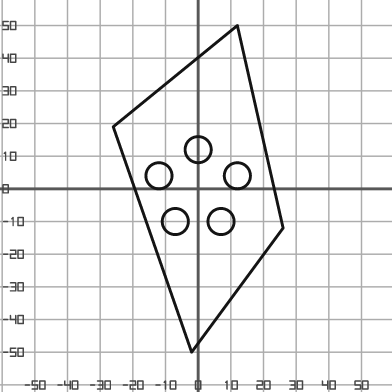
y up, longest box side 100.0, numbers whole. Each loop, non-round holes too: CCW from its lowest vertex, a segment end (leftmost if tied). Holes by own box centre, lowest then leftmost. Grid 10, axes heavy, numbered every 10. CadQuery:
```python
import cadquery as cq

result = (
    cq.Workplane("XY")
    .moveTo(-2.0, -50.0)
    .lineTo(26.0, -12.0)
    .lineTo(12.0, 50.0)
    .lineTo(-26.0, 19.0)
    .close()
    .moveTo(-7.0, -10.0)
    .circle(4.0)
    .moveTo(7.0, -10.0)
    .circle(4.0)
    .moveTo(-12.0, 4.0)
    .circle(4.0)
    .moveTo(12.0, 4.0)
    .circle(4.0)
    .moveTo(0.0, 12.0)
    .circle(4.0)
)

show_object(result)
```